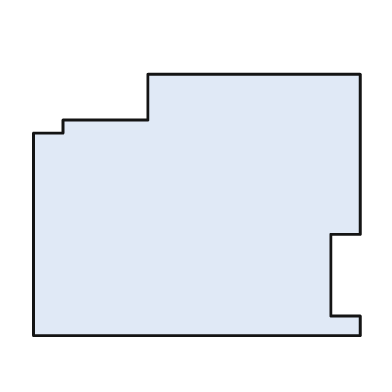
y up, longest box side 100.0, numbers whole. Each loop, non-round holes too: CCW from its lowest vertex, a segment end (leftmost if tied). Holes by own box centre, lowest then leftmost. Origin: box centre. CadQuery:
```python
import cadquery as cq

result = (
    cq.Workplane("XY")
    .moveTo(-50.0, -40.0)
    .lineTo(50.0, -40.0)
    .lineTo(50.0, -34.0)
    .lineTo(41.0, -34.0)
    .lineTo(41.0, -9.0)
    .lineTo(50.0, -9.0)
    .lineTo(50.0, 40.0)
    .lineTo(-15.0, 40.0)
    .lineTo(-15.0, 26.0)
    .lineTo(-41.0, 26.0)
    .lineTo(-41.0, 22.0)
    .lineTo(-50.0, 22.0)
    .close()
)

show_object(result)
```